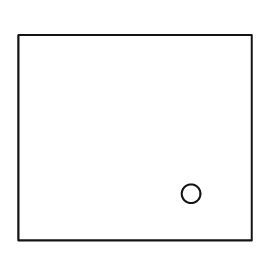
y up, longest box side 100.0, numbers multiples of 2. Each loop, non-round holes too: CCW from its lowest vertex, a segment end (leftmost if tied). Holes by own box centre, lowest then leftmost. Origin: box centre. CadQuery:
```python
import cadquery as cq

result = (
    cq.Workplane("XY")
    .moveTo(-50.0, -44.0)
    .lineTo(50.0, -44.0)
    .lineTo(50.0, 44.0)
    .lineTo(-50.0, 44.0)
    .close()
    .moveTo(24.0, -24.0)
    .circle(4.0)
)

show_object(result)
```